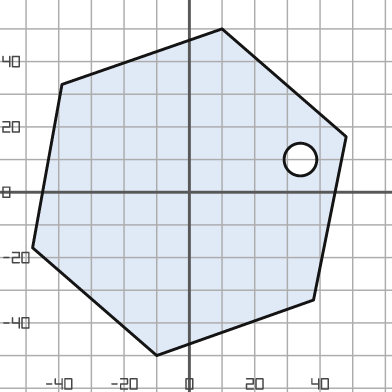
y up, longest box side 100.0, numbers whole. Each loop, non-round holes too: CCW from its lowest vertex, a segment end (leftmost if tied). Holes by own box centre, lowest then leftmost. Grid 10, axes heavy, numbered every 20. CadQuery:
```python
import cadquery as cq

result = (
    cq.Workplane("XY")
    .moveTo(-10.0, -50.0)
    .lineTo(38.0, -33.0)
    .lineTo(48.0, 17.0)
    .lineTo(10.0, 50.0)
    .lineTo(-39.0, 33.0)
    .lineTo(-48.0, -17.0)
    .close()
    .moveTo(34.0, 10.0)
    .circle(5.0)
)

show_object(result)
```